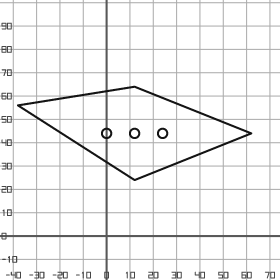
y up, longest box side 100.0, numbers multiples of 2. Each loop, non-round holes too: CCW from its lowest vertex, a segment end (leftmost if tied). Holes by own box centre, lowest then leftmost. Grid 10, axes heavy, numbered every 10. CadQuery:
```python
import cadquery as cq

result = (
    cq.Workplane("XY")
    .moveTo(12.0, 24.0)
    .lineTo(62.0, 44.0)
    .lineTo(12.0, 64.0)
    .lineTo(-38.0, 56.0)
    .close()
    .moveTo(0.0, 44.0)
    .circle(2.0)
    .moveTo(12.0, 44.0)
    .circle(2.0)
    .moveTo(24.0, 44.0)
    .circle(2.0)
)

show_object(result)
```